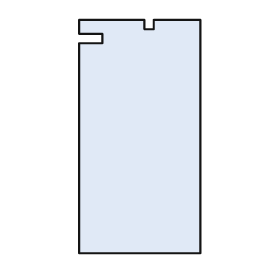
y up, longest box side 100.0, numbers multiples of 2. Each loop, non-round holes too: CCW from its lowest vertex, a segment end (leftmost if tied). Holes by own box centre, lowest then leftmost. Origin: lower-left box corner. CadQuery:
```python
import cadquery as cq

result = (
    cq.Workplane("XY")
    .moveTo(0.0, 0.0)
    .lineTo(52.0, 0.0)
    .lineTo(52.0, 100.0)
    .lineTo(32.0, 100.0)
    .lineTo(32.0, 96.0)
    .lineTo(28.0, 96.0)
    .lineTo(28.0, 100.0)
    .lineTo(0.0, 100.0)
    .lineTo(0.0, 94.0)
    .lineTo(10.0, 94.0)
    .lineTo(10.0, 90.0)
    .lineTo(0.0, 90.0)
    .close()
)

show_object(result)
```